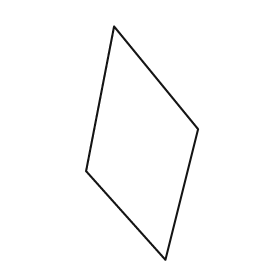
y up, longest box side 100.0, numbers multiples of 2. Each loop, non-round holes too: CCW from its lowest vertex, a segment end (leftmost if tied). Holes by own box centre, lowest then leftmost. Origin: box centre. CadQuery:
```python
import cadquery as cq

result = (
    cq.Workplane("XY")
    .moveTo(10.0, -50.0)
    .lineTo(24.0, 6.0)
    .lineTo(-12.0, 50.0)
    .lineTo(-24.0, -12.0)
    .close()
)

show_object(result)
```